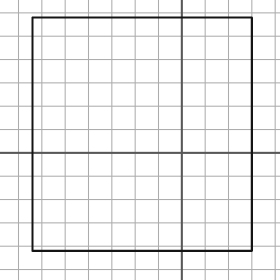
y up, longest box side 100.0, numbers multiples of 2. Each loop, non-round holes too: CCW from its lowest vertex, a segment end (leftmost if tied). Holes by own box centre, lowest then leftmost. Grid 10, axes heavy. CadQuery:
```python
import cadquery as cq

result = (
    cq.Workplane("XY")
    .moveTo(-64.0, -42.0)
    .lineTo(30.0, -42.0)
    .lineTo(30.0, 58.0)
    .lineTo(-64.0, 58.0)
    .close()
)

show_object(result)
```